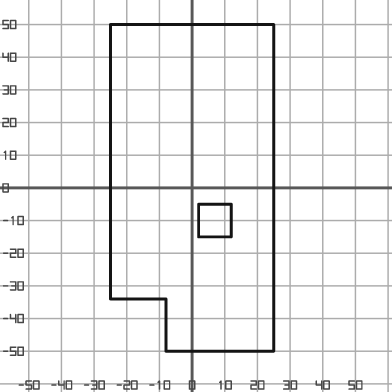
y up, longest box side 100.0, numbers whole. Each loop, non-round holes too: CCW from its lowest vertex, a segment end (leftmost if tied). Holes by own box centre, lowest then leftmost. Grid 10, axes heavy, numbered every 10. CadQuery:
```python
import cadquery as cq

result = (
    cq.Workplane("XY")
    .moveTo(-8.0, -50.0)
    .lineTo(25.0, -50.0)
    .lineTo(25.0, 50.0)
    .lineTo(-25.0, 50.0)
    .lineTo(-25.0, -34.0)
    .lineTo(-8.0, -34.0)
    .close()
    .moveTo(2.0, -15.0)
    .lineTo(12.0, -15.0)
    .lineTo(12.0, -5.0)
    .lineTo(2.0, -5.0)
    .close()
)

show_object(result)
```